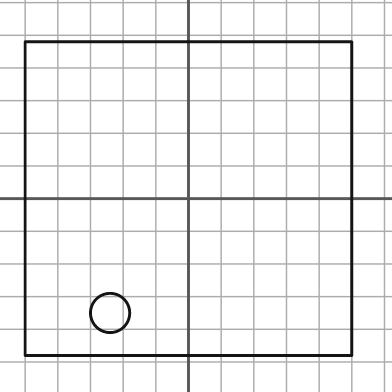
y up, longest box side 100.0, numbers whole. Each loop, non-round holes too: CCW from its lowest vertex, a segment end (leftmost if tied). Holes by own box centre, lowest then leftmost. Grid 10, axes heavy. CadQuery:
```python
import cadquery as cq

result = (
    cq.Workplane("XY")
    .moveTo(-50.0, -48.0)
    .lineTo(50.0, -48.0)
    .lineTo(50.0, 48.0)
    .lineTo(-50.0, 48.0)
    .close()
    .moveTo(-24.0, -35.0)
    .circle(6.0)
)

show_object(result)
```